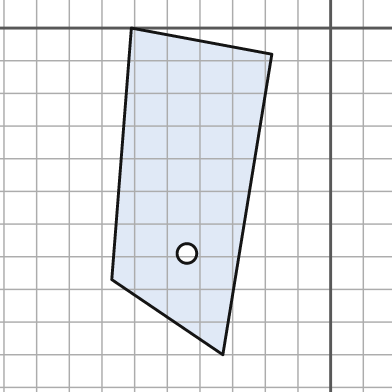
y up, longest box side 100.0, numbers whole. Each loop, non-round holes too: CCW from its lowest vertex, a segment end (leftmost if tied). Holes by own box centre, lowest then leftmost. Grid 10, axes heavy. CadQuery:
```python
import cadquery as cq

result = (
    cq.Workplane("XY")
    .moveTo(-33.0, -100.0)
    .lineTo(-18.0, -8.0)
    .lineTo(-61.0, 0.0)
    .lineTo(-67.0, -77.0)
    .close()
    .moveTo(-44.0, -69.0)
    .circle(3.0)
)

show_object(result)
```